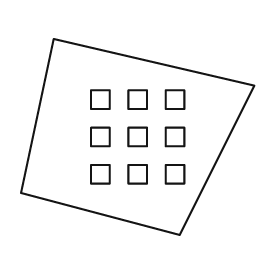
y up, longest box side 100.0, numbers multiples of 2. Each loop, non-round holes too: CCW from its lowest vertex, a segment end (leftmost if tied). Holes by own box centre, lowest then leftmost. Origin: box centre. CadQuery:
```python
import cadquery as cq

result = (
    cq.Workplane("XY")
    .moveTo(18.0, -42.0)
    .lineTo(50.0, 22.0)
    .lineTo(-36.0, 42.0)
    .lineTo(-50.0, -24.0)
    .close()
    .moveTo(-20.0, -20.0)
    .lineTo(-12.0, -20.0)
    .lineTo(-12.0, -12.0)
    .lineTo(-20.0, -12.0)
    .close()
    .moveTo(-4.0, -20.0)
    .lineTo(4.0, -20.0)
    .lineTo(4.0, -12.0)
    .lineTo(-4.0, -12.0)
    .close()
    .moveTo(12.0, -20.0)
    .lineTo(20.0, -20.0)
    .lineTo(20.0, -12.0)
    .lineTo(12.0, -12.0)
    .close()
    .moveTo(-20.0, -4.0)
    .lineTo(-12.0, -4.0)
    .lineTo(-12.0, 4.0)
    .lineTo(-20.0, 4.0)
    .close()
    .moveTo(-4.0, -4.0)
    .lineTo(4.0, -4.0)
    .lineTo(4.0, 4.0)
    .lineTo(-4.0, 4.0)
    .close()
    .moveTo(12.0, -4.0)
    .lineTo(20.0, -4.0)
    .lineTo(20.0, 4.0)
    .lineTo(12.0, 4.0)
    .close()
    .moveTo(-20.0, 12.0)
    .lineTo(-12.0, 12.0)
    .lineTo(-12.0, 20.0)
    .lineTo(-20.0, 20.0)
    .close()
    .moveTo(-4.0, 12.0)
    .lineTo(4.0, 12.0)
    .lineTo(4.0, 20.0)
    .lineTo(-4.0, 20.0)
    .close()
    .moveTo(12.0, 12.0)
    .lineTo(20.0, 12.0)
    .lineTo(20.0, 20.0)
    .lineTo(12.0, 20.0)
    .close()
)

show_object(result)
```